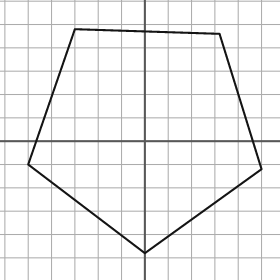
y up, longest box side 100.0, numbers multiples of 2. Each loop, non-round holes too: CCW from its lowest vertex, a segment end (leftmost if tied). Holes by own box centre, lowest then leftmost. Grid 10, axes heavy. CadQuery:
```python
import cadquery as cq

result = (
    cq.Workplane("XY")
    .moveTo(0.0, -48.0)
    .lineTo(50.0, -12.0)
    .lineTo(32.0, 46.0)
    .lineTo(-30.0, 48.0)
    .lineTo(-50.0, -10.0)
    .close()
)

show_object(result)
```